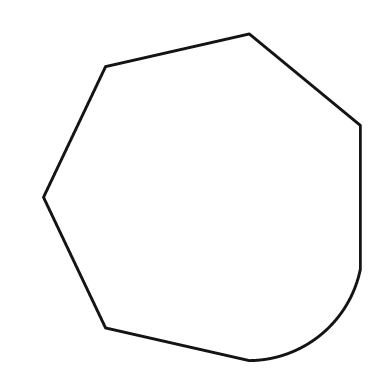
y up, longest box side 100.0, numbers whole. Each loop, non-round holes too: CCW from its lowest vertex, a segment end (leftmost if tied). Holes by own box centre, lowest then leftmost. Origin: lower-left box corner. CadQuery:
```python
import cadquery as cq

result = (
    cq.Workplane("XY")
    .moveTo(63.0, 0.0)
    .threePointArc((85.0, 8.0), (97.0, 28.0))
    .lineTo(97.0, 72.0)
    .lineTo(63.0, 100.0)
    .lineTo(19.0, 90.0)
    .lineTo(0.0, 50.0)
    .lineTo(19.0, 10.0)
    .close()
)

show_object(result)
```